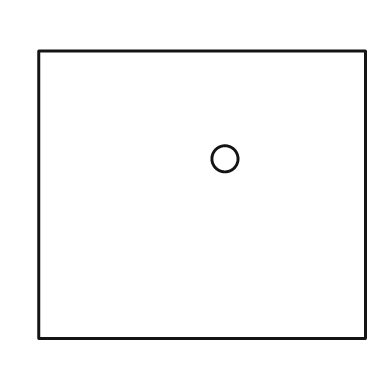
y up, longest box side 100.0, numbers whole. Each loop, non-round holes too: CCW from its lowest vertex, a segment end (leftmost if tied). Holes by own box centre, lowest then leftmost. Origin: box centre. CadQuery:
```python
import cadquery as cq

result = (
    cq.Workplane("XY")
    .moveTo(-50.0, -44.0)
    .lineTo(50.0, -44.0)
    .lineTo(50.0, 44.0)
    .lineTo(-50.0, 44.0)
    .close()
    .moveTo(7.0, 11.0)
    .circle(4.0)
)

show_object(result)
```